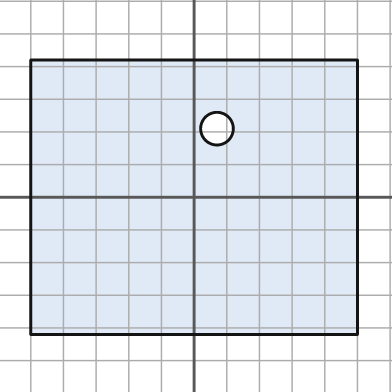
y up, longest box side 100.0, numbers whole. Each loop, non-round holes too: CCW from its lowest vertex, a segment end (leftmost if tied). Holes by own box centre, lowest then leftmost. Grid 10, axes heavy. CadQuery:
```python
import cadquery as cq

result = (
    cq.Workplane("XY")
    .moveTo(-50.0, -42.0)
    .lineTo(50.0, -42.0)
    .lineTo(50.0, 42.0)
    .lineTo(-50.0, 42.0)
    .close()
    .moveTo(7.0, 21.0)
    .circle(5.0)
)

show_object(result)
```